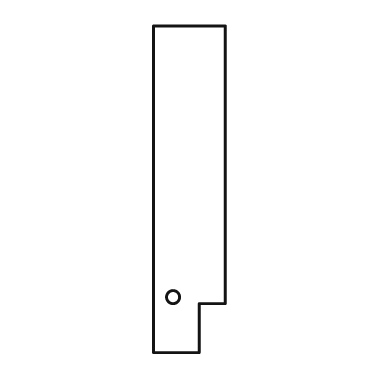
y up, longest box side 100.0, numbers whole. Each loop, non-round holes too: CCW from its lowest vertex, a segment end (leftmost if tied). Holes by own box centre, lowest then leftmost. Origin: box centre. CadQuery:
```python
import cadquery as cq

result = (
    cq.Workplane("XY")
    .moveTo(-11.0, -50.0)
    .lineTo(3.0, -50.0)
    .lineTo(3.0, -35.0)
    .lineTo(11.0, -35.0)
    .lineTo(11.0, 50.0)
    .lineTo(-11.0, 50.0)
    .close()
    .moveTo(-5.0, -33.0)
    .circle(2.0)
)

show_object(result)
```